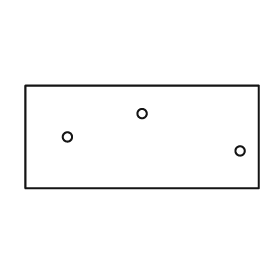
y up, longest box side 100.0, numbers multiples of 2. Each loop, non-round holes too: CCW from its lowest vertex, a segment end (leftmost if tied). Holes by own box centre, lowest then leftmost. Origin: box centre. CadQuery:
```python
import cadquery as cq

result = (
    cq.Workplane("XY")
    .moveTo(-50.0, -22.0)
    .lineTo(50.0, -22.0)
    .lineTo(50.0, 22.0)
    .lineTo(-50.0, 22.0)
    .close()
    .moveTo(42.0, -6.0)
    .circle(2.0)
    .moveTo(-32.0, 0.0)
    .circle(2.0)
    .moveTo(0.0, 10.0)
    .circle(2.0)
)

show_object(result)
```